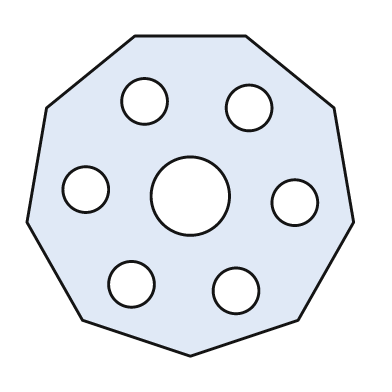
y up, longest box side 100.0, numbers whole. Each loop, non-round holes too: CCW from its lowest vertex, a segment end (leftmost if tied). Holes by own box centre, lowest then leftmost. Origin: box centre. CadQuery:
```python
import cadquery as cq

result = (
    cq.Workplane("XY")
    .moveTo(0.0, -49.0)
    .lineTo(33.0, -38.0)
    .lineTo(50.0, -8.0)
    .lineTo(44.0, 27.0)
    .lineTo(17.0, 49.0)
    .lineTo(-17.0, 49.0)
    .lineTo(-44.0, 27.0)
    .lineTo(-50.0, -8.0)
    .lineTo(-33.0, -38.0)
    .close()
    .moveTo(14.0, -29.0)
    .circle(7.0)
    .moveTo(-18.0, -27.0)
    .circle(7.0)
    .moveTo(32.0, -2.0)
    .circle(7.0)
    .moveTo(0.0, 0.0)
    .circle(12.0)
    .moveTo(-32.0, 2.0)
    .circle(7.0)
    .moveTo(18.0, 27.0)
    .circle(7.0)
    .moveTo(-14.0, 29.0)
    .circle(7.0)
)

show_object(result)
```